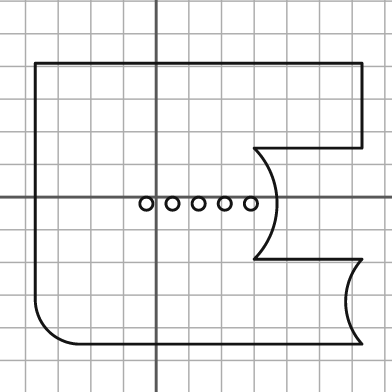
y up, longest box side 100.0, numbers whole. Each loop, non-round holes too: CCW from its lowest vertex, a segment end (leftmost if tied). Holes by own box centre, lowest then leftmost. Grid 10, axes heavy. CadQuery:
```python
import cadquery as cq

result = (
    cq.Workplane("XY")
    .moveTo(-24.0, -45.0)
    .lineTo(63.0, -45.0)
    .threePointArc((58.0, -32.0), (63.0, -19.0))
    .lineTo(30.0, -19.0)
    .threePointArc((37.0, -2.0), (30.0, 15.0))
    .lineTo(63.0, 15.0)
    .lineTo(63.0, 41.0)
    .lineTo(-37.0, 41.0)
    .lineTo(-37.0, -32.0)
    .threePointArc((-33.0, -41.0), (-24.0, -45.0))
    .close()
    .moveTo(-3.0, -2.0)
    .circle(2.0)
    .moveTo(5.0, -2.0)
    .circle(2.0)
    .moveTo(13.0, -2.0)
    .circle(2.0)
    .moveTo(21.0, -2.0)
    .circle(2.0)
    .moveTo(29.0, -2.0)
    .circle(2.0)
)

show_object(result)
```